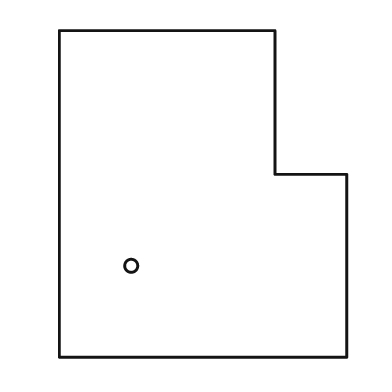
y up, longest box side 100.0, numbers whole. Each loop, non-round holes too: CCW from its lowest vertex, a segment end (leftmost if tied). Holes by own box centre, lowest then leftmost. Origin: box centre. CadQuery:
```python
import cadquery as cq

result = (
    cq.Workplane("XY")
    .moveTo(-44.0, -50.0)
    .lineTo(44.0, -50.0)
    .lineTo(44.0, 6.0)
    .lineTo(22.0, 6.0)
    .lineTo(22.0, 50.0)
    .lineTo(-44.0, 50.0)
    .close()
    .moveTo(-22.0, -22.0)
    .circle(2.0)
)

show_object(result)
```